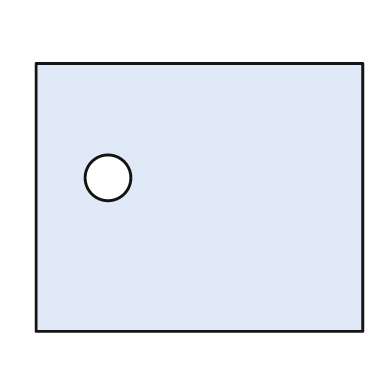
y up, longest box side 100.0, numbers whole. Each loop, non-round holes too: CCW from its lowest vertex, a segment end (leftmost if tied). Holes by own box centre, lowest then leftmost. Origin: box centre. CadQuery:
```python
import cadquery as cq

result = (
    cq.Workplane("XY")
    .moveTo(-50.0, -41.0)
    .lineTo(50.0, -41.0)
    .lineTo(50.0, 41.0)
    .lineTo(-50.0, 41.0)
    .close()
    .moveTo(-28.0, 6.0)
    .circle(7.0)
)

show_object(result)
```